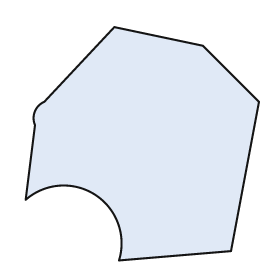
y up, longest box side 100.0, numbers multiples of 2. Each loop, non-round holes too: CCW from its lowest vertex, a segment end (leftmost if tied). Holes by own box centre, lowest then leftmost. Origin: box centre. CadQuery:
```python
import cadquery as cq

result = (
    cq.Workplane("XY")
    .moveTo(-10.0, -50.0)
    .lineTo(38.0, -46.0)
    .lineTo(50.0, 18.0)
    .lineTo(26.0, 42.0)
    .lineTo(-12.0, 50.0)
    .lineTo(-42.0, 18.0)
    .threePointArc((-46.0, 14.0), (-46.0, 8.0))
    .lineTo(-50.0, -24.0)
    .threePointArc((-20.0, -22.0), (-10.0, -50.0))
    .close()
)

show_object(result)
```